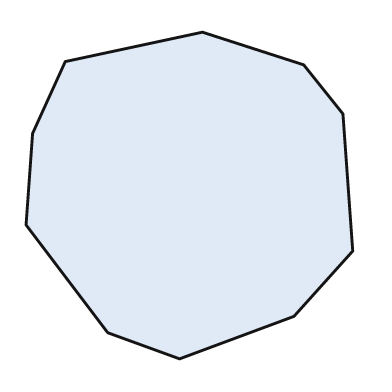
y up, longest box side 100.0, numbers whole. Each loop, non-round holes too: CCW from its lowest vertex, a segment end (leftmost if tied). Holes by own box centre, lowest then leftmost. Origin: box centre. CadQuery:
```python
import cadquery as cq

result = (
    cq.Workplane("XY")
    .moveTo(-3.0, -50.0)
    .lineTo(32.0, -37.0)
    .lineTo(50.0, -17.0)
    .lineTo(47.0, 25.0)
    .lineTo(35.0, 40.0)
    .lineTo(4.0, 50.0)
    .lineTo(-38.0, 41.0)
    .lineTo(-48.0, 19.0)
    .lineTo(-50.0, -9.0)
    .lineTo(-25.0, -42.0)
    .close()
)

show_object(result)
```